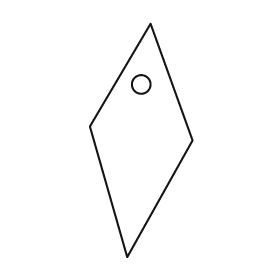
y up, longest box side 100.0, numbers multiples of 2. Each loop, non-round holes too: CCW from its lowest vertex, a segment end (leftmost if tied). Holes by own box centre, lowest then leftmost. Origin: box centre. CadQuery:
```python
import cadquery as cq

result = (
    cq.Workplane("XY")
    .moveTo(-6.0, -50.0)
    .lineTo(22.0, 0.0)
    .lineTo(4.0, 50.0)
    .lineTo(-22.0, 6.0)
    .close()
    .moveTo(0.0, 24.0)
    .circle(4.0)
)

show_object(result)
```